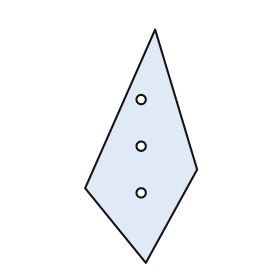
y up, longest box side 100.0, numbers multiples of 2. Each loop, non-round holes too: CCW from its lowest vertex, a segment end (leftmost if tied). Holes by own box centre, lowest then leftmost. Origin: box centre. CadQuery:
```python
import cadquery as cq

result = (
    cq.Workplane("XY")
    .moveTo(2.0, -50.0)
    .lineTo(24.0, -10.0)
    .lineTo(6.0, 50.0)
    .lineTo(-24.0, -18.0)
    .close()
    .moveTo(0.0, -20.0)
    .circle(2.0)
    .moveTo(0.0, 0.0)
    .circle(2.0)
    .moveTo(0.0, 20.0)
    .circle(2.0)
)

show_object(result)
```